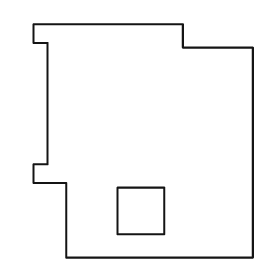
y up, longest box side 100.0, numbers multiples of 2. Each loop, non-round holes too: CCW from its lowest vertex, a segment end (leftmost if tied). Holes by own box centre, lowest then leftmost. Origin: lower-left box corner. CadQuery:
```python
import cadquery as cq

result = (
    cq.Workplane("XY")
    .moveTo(14.0, 0.0)
    .lineTo(94.0, 0.0)
    .lineTo(94.0, 90.0)
    .lineTo(64.0, 90.0)
    .lineTo(64.0, 100.0)
    .lineTo(0.0, 100.0)
    .lineTo(0.0, 92.0)
    .lineTo(6.0, 92.0)
    .lineTo(6.0, 40.0)
    .lineTo(0.0, 40.0)
    .lineTo(0.0, 32.0)
    .lineTo(14.0, 32.0)
    .close()
    .moveTo(36.0, 10.0)
    .lineTo(56.0, 10.0)
    .lineTo(56.0, 30.0)
    .lineTo(36.0, 30.0)
    .close()
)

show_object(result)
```